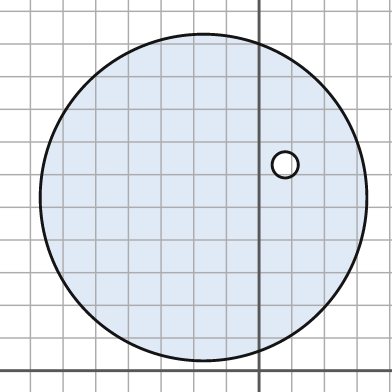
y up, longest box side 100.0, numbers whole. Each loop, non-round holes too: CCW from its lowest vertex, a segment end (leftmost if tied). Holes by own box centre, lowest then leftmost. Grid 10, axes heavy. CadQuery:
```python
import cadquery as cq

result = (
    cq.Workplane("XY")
    .moveTo(-17.0, 53.0)
    .circle(50.0)
    .moveTo(8.0, 63.0)
    .circle(4.0)
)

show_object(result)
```